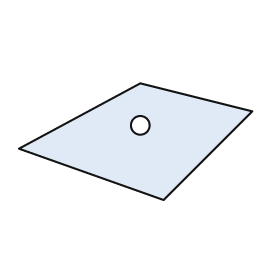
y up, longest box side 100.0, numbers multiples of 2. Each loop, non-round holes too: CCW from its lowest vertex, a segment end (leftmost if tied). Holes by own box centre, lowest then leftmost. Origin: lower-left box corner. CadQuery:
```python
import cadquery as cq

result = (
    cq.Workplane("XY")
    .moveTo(62.0, 0.0)
    .lineTo(100.0, 38.0)
    .lineTo(52.0, 50.0)
    .lineTo(0.0, 22.0)
    .close()
    .moveTo(52.0, 32.0)
    .circle(4.0)
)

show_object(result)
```